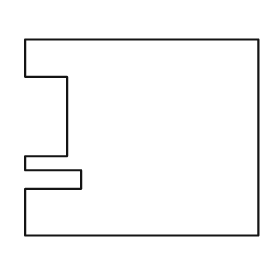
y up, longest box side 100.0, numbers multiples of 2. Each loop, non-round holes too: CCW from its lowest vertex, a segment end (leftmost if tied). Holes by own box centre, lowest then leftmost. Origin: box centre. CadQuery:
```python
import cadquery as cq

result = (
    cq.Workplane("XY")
    .moveTo(-50.0, -42.0)
    .lineTo(50.0, -42.0)
    .lineTo(50.0, 42.0)
    .lineTo(-50.0, 42.0)
    .lineTo(-50.0, 26.0)
    .lineTo(-32.0, 26.0)
    .lineTo(-32.0, -8.0)
    .lineTo(-50.0, -8.0)
    .lineTo(-50.0, -14.0)
    .lineTo(-26.0, -14.0)
    .lineTo(-26.0, -22.0)
    .lineTo(-50.0, -22.0)
    .close()
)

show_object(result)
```